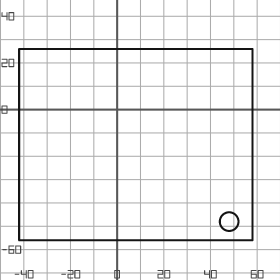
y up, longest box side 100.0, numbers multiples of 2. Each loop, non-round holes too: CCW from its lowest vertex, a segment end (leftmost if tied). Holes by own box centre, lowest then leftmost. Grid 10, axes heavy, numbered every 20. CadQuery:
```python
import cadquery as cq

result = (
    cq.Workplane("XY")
    .moveTo(-42.0, -56.0)
    .lineTo(58.0, -56.0)
    .lineTo(58.0, 26.0)
    .lineTo(-42.0, 26.0)
    .close()
    .moveTo(48.0, -48.0)
    .circle(4.0)
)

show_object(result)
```